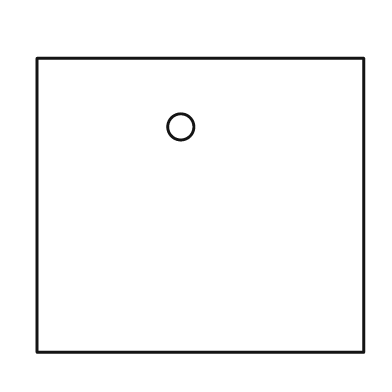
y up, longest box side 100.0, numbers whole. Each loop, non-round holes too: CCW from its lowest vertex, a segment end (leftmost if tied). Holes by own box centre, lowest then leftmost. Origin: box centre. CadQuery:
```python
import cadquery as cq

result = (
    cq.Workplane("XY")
    .moveTo(-50.0, -45.0)
    .lineTo(50.0, -45.0)
    .lineTo(50.0, 45.0)
    .lineTo(-50.0, 45.0)
    .close()
    .moveTo(-6.0, 24.0)
    .circle(4.0)
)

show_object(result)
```